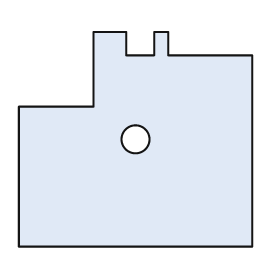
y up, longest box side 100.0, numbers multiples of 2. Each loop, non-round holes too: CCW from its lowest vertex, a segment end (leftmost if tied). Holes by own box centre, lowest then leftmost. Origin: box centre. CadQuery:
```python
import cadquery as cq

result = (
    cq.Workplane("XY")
    .moveTo(-50.0, -46.0)
    .lineTo(50.0, -46.0)
    .lineTo(50.0, 36.0)
    .lineTo(14.0, 36.0)
    .lineTo(14.0, 46.0)
    .lineTo(8.0, 46.0)
    .lineTo(8.0, 36.0)
    .lineTo(-4.0, 36.0)
    .lineTo(-4.0, 46.0)
    .lineTo(-18.0, 46.0)
    .lineTo(-18.0, 14.0)
    .lineTo(-50.0, 14.0)
    .close()
    .moveTo(0.0, 0.0)
    .circle(6.0)
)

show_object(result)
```